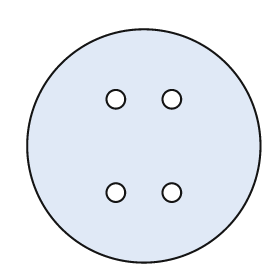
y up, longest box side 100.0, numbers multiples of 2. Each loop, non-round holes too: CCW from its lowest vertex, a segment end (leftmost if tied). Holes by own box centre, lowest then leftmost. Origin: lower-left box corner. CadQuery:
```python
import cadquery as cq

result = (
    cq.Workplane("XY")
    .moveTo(50.0, 50.0)
    .circle(50.0)
    .moveTo(38.0, 30.0)
    .circle(4.0)
    .moveTo(62.0, 30.0)
    .circle(4.0)
    .moveTo(38.0, 70.0)
    .circle(4.0)
    .moveTo(62.0, 70.0)
    .circle(4.0)
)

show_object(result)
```